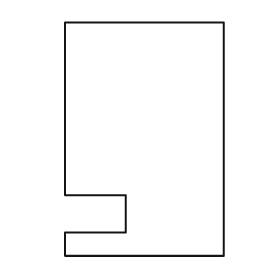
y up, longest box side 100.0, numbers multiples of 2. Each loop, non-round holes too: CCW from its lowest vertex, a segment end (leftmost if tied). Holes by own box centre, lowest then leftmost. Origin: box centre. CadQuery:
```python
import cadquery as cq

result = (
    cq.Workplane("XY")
    .moveTo(-34.0, -50.0)
    .lineTo(34.0, -50.0)
    .lineTo(34.0, 50.0)
    .lineTo(-34.0, 50.0)
    .lineTo(-34.0, -24.0)
    .lineTo(-8.0, -24.0)
    .lineTo(-8.0, -40.0)
    .lineTo(-34.0, -40.0)
    .close()
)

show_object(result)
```